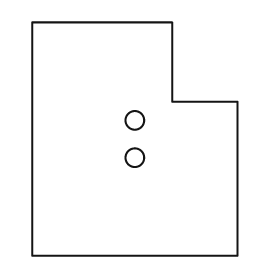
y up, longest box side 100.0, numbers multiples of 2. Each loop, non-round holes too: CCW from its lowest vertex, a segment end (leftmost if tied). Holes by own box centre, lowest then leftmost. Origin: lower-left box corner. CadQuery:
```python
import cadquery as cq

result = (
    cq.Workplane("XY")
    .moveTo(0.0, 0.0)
    .lineTo(88.0, 0.0)
    .lineTo(88.0, 66.0)
    .lineTo(60.0, 66.0)
    .lineTo(60.0, 100.0)
    .lineTo(0.0, 100.0)
    .close()
    .moveTo(44.0, 42.0)
    .circle(4.0)
    .moveTo(44.0, 58.0)
    .circle(4.0)
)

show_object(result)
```